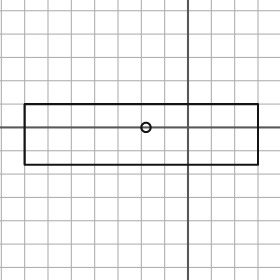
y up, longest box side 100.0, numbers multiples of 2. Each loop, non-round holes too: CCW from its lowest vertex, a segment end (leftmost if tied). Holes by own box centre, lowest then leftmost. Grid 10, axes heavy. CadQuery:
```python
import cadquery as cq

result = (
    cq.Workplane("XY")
    .moveTo(-70.0, -16.0)
    .lineTo(30.0, -16.0)
    .lineTo(30.0, 10.0)
    .lineTo(-70.0, 10.0)
    .close()
    .moveTo(-18.0, 0.0)
    .circle(2.0)
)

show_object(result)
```